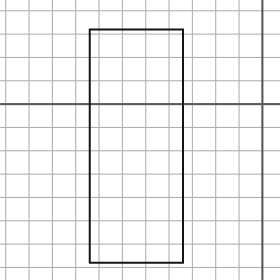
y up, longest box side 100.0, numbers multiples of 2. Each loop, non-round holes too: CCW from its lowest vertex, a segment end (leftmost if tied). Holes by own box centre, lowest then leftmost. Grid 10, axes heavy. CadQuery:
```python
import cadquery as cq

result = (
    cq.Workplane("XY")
    .moveTo(-74.0, -68.0)
    .lineTo(-34.0, -68.0)
    .lineTo(-34.0, 32.0)
    .lineTo(-74.0, 32.0)
    .close()
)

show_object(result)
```